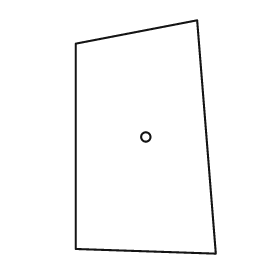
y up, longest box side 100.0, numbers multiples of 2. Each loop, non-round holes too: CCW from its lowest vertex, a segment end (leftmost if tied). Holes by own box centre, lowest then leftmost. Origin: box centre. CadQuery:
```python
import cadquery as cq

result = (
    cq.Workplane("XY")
    .moveTo(30.0, -50.0)
    .lineTo(22.0, 50.0)
    .lineTo(-30.0, 40.0)
    .lineTo(-30.0, -48.0)
    .close()
    .moveTo(0.0, 0.0)
    .circle(2.0)
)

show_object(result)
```